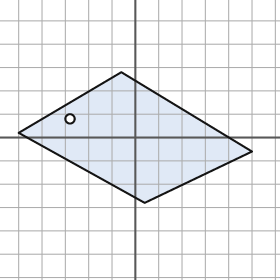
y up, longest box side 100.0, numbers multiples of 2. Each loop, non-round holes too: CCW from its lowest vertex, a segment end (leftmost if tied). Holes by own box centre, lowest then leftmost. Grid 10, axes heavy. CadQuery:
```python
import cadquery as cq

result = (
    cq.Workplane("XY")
    .moveTo(4.0, -28.0)
    .lineTo(50.0, -6.0)
    .lineTo(-6.0, 28.0)
    .lineTo(-50.0, 2.0)
    .close()
    .moveTo(-28.0, 8.0)
    .circle(2.0)
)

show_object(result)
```